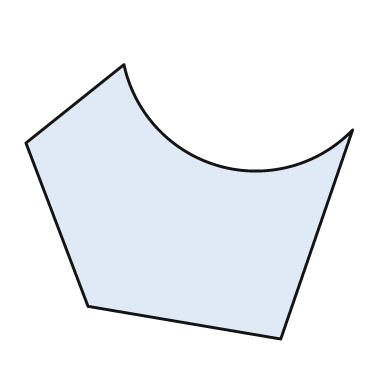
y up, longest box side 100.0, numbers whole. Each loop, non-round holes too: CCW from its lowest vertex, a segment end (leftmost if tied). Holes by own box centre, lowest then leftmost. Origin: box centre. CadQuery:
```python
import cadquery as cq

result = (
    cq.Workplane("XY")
    .moveTo(28.0, -42.0)
    .lineTo(50.0, 22.0)
    .threePointArc((9.0, 11.0), (-20.0, 42.0))
    .lineTo(-50.0, 18.0)
    .lineTo(-31.0, -32.0)
    .close()
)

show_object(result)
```